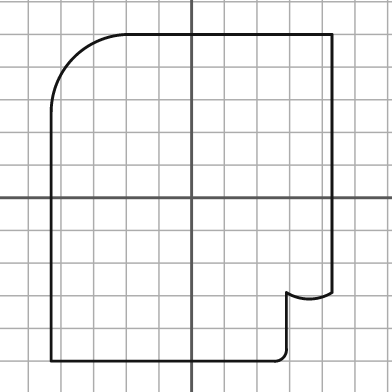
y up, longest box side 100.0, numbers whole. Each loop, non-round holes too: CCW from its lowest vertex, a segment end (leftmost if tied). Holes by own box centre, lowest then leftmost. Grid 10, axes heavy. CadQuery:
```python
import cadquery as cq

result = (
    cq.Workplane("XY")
    .moveTo(-43.0, -50.0)
    .lineTo(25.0, -50.0)
    .threePointArc((28.0, -49.0), (29.0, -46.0))
    .lineTo(29.0, -29.0)
    .threePointArc((36.0, -31.0), (43.0, -29.0))
    .lineTo(43.0, 50.0)
    .lineTo(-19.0, 50.0)
    .threePointArc((-36.0, 43.0), (-43.0, 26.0))
    .close()
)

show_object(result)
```